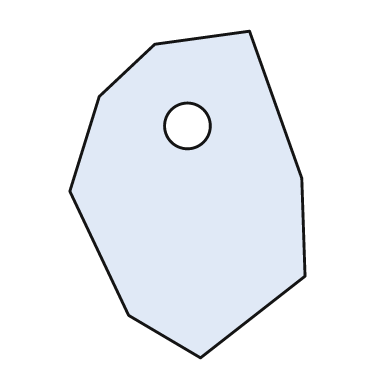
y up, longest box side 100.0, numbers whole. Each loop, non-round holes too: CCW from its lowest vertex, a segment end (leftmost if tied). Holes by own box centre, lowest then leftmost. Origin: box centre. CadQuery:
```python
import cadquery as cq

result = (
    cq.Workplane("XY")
    .moveTo(4.0, -50.0)
    .lineTo(36.0, -25.0)
    .lineTo(35.0, 5.0)
    .lineTo(19.0, 50.0)
    .lineTo(-10.0, 46.0)
    .lineTo(-27.0, 30.0)
    .lineTo(-36.0, 1.0)
    .lineTo(-18.0, -37.0)
    .close()
    .moveTo(0.0, 21.0)
    .circle(7.0)
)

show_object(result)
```